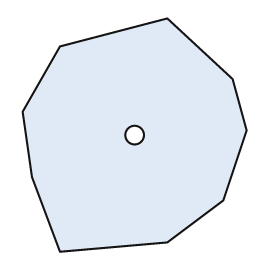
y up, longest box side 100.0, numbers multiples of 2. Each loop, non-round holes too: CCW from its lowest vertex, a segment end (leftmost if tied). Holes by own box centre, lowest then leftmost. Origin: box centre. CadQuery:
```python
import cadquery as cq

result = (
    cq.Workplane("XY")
    .moveTo(-32.0, -50.0)
    .lineTo(14.0, -46.0)
    .lineTo(38.0, -28.0)
    .lineTo(48.0, 2.0)
    .lineTo(42.0, 24.0)
    .lineTo(14.0, 50.0)
    .lineTo(-32.0, 38.0)
    .lineTo(-48.0, 10.0)
    .lineTo(-44.0, -18.0)
    .close()
    .moveTo(0.0, 0.0)
    .circle(4.0)
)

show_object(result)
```